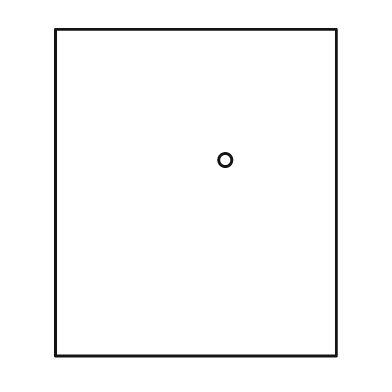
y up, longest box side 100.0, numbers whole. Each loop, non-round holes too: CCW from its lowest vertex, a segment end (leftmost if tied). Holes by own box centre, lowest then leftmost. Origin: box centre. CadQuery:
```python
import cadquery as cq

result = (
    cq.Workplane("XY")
    .moveTo(-43.0, -50.0)
    .lineTo(43.0, -50.0)
    .lineTo(43.0, 50.0)
    .lineTo(-43.0, 50.0)
    .close()
    .moveTo(9.0, 10.0)
    .circle(2.0)
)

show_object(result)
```